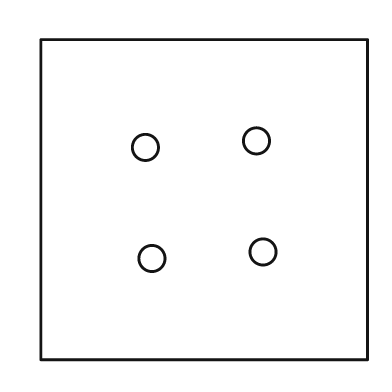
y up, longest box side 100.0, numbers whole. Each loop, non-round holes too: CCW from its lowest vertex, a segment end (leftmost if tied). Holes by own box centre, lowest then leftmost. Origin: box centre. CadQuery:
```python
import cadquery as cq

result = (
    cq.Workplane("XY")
    .moveTo(-50.0, -49.0)
    .lineTo(50.0, -49.0)
    .lineTo(50.0, 49.0)
    .lineTo(-50.0, 49.0)
    .close()
    .moveTo(-16.0, -18.0)
    .circle(4.0)
    .moveTo(18.0, -16.0)
    .circle(4.0)
    .moveTo(-18.0, 16.0)
    .circle(4.0)
    .moveTo(16.0, 18.0)
    .circle(4.0)
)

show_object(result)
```